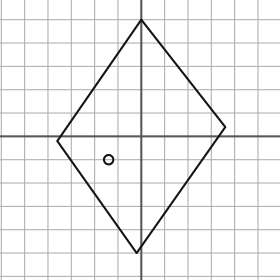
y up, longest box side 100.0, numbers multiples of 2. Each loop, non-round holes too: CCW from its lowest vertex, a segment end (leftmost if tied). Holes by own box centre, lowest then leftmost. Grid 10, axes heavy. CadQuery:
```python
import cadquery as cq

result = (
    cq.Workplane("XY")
    .moveTo(-2.0, -50.0)
    .lineTo(36.0, 4.0)
    .lineTo(0.0, 50.0)
    .lineTo(-36.0, -2.0)
    .close()
    .moveTo(-14.0, -10.0)
    .circle(2.0)
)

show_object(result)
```